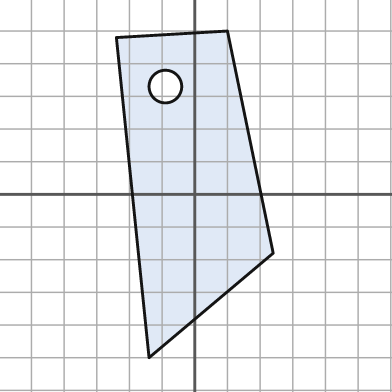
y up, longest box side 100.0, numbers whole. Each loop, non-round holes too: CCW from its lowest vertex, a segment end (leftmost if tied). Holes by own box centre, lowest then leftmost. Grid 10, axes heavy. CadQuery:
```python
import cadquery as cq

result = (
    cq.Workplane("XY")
    .moveTo(-14.0, -50.0)
    .lineTo(24.0, -18.0)
    .lineTo(10.0, 50.0)
    .lineTo(-24.0, 48.0)
    .close()
    .moveTo(-9.0, 33.0)
    .circle(5.0)
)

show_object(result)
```